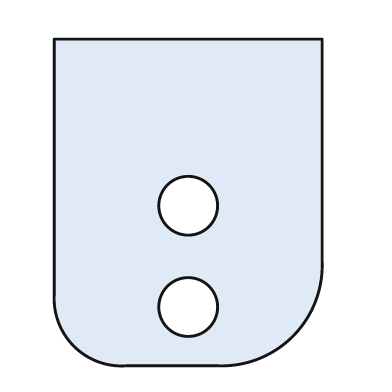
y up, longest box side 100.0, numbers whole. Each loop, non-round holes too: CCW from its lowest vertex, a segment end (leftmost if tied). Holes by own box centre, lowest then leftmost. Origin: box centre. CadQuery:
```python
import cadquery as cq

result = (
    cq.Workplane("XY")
    .moveTo(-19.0, -50.0)
    .lineTo(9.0, -50.0)
    .threePointArc((32.0, -41.0), (41.0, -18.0))
    .lineTo(41.0, 50.0)
    .lineTo(-41.0, 50.0)
    .lineTo(-41.0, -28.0)
    .threePointArc((-35.0, -44.0), (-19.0, -50.0))
    .close()
    .moveTo(0.0, -32.0)
    .circle(9.0)
    .moveTo(0.0, -1.0)
    .circle(9.0)
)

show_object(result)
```